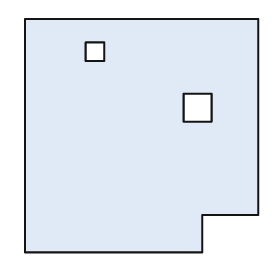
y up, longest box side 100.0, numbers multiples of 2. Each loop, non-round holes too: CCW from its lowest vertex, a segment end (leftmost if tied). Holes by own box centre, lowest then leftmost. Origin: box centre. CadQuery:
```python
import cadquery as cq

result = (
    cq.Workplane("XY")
    .moveTo(-50.0, -50.0)
    .lineTo(26.0, -50.0)
    .lineTo(26.0, -34.0)
    .lineTo(50.0, -34.0)
    .lineTo(50.0, 50.0)
    .lineTo(-50.0, 50.0)
    .close()
    .moveTo(18.0, 6.0)
    .lineTo(30.0, 6.0)
    .lineTo(30.0, 18.0)
    .lineTo(18.0, 18.0)
    .close()
    .moveTo(-24.0, 32.0)
    .lineTo(-16.0, 32.0)
    .lineTo(-16.0, 40.0)
    .lineTo(-24.0, 40.0)
    .close()
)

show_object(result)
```